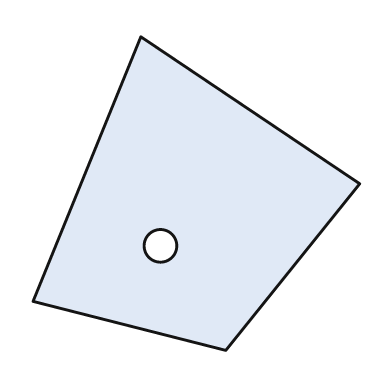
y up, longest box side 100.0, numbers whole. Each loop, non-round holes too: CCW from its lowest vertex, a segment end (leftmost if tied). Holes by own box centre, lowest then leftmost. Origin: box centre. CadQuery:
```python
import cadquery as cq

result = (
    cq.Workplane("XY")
    .moveTo(9.0, -48.0)
    .lineTo(50.0, 3.0)
    .lineTo(-17.0, 48.0)
    .lineTo(-50.0, -33.0)
    .close()
    .moveTo(-11.0, -16.0)
    .circle(5.0)
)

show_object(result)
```